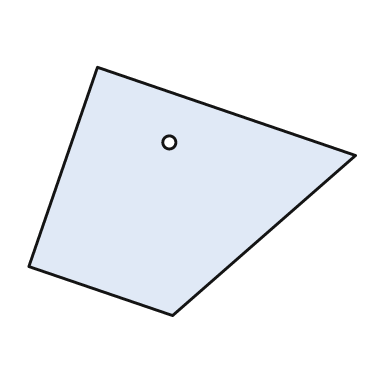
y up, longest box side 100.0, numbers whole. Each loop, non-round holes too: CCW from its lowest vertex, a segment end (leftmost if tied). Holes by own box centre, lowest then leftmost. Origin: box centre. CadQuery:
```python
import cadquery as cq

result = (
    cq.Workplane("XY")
    .moveTo(-6.0, -38.0)
    .lineTo(50.0, 11.0)
    .lineTo(-29.0, 38.0)
    .lineTo(-50.0, -23.0)
    .close()
    .moveTo(-7.0, 15.0)
    .circle(2.0)
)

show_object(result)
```